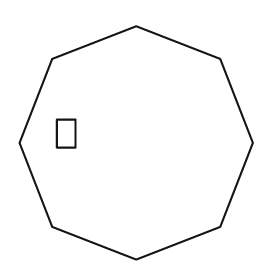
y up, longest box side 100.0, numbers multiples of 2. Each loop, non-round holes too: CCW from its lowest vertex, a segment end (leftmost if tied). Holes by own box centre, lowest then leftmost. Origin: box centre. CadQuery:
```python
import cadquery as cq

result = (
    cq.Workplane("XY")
    .moveTo(0.0, -50.0)
    .lineTo(36.0, -36.0)
    .lineTo(50.0, 0.0)
    .lineTo(36.0, 36.0)
    .lineTo(0.0, 50.0)
    .lineTo(-36.0, 36.0)
    .lineTo(-50.0, 0.0)
    .lineTo(-36.0, -36.0)
    .close()
    .moveTo(-34.0, -2.0)
    .lineTo(-26.0, -2.0)
    .lineTo(-26.0, 10.0)
    .lineTo(-34.0, 10.0)
    .close()
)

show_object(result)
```